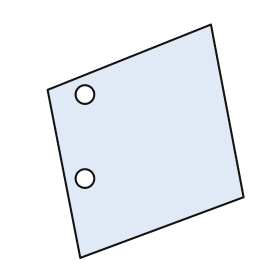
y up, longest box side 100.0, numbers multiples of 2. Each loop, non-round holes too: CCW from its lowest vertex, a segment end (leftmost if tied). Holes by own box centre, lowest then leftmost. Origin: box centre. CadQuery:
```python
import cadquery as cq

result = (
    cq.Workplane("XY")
    .moveTo(-28.0, -50.0)
    .lineTo(42.0, -24.0)
    .lineTo(28.0, 50.0)
    .lineTo(-42.0, 22.0)
    .close()
    .moveTo(-26.0, -16.0)
    .circle(4.0)
    .moveTo(-26.0, 20.0)
    .circle(4.0)
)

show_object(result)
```